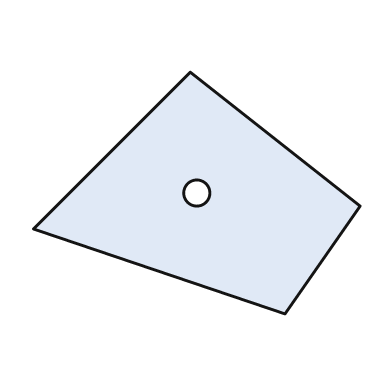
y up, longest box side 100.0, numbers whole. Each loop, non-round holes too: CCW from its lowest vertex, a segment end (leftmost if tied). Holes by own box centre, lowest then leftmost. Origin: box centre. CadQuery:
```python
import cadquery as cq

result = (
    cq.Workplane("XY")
    .moveTo(27.0, -37.0)
    .lineTo(50.0, -4.0)
    .lineTo(-2.0, 37.0)
    .lineTo(-50.0, -11.0)
    .close()
    .moveTo(0.0, 0.0)
    .circle(4.0)
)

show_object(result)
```